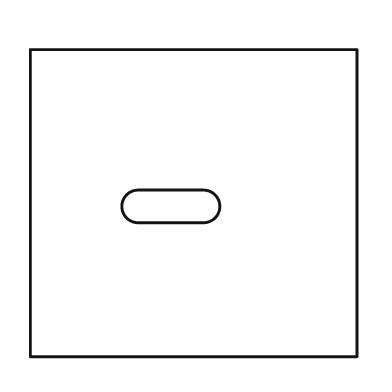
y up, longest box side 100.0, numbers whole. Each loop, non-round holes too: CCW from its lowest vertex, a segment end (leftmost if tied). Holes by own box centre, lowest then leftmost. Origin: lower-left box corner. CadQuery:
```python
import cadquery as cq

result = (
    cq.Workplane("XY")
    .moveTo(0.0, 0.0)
    .lineTo(100.0, 0.0)
    .lineTo(100.0, 94.0)
    .lineTo(0.0, 94.0)
    .close()
    .moveTo(33.0, 41.0)
    .lineTo(53.0, 41.0)
    .threePointArc((58.0, 46.0), (53.0, 51.0))
    .lineTo(33.0, 51.0)
    .threePointArc((28.0, 46.0), (33.0, 41.0))
    .close()
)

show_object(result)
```